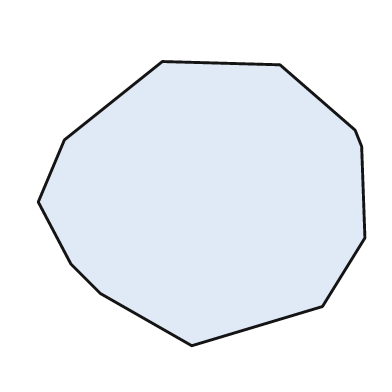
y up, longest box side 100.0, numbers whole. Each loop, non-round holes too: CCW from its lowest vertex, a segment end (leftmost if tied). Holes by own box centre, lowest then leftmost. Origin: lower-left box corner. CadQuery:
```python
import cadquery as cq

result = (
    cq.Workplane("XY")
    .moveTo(47.0, 0.0)
    .lineTo(87.0, 12.0)
    .lineTo(100.0, 33.0)
    .lineTo(99.0, 61.0)
    .lineTo(97.0, 66.0)
    .lineTo(74.0, 86.0)
    .lineTo(38.0, 87.0)
    .lineTo(8.0, 63.0)
    .lineTo(0.0, 44.0)
    .lineTo(10.0, 25.0)
    .lineTo(19.0, 16.0)
    .close()
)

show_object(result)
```